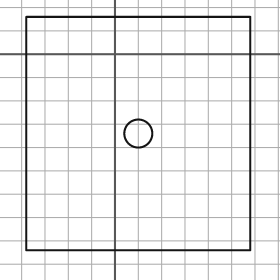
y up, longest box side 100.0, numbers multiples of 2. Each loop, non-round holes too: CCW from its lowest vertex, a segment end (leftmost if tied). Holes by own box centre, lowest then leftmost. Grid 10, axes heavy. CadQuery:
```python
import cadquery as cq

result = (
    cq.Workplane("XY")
    .moveTo(-38.0, -84.0)
    .lineTo(58.0, -84.0)
    .lineTo(58.0, 16.0)
    .lineTo(-38.0, 16.0)
    .close()
    .moveTo(10.0, -34.0)
    .circle(6.0)
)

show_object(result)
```